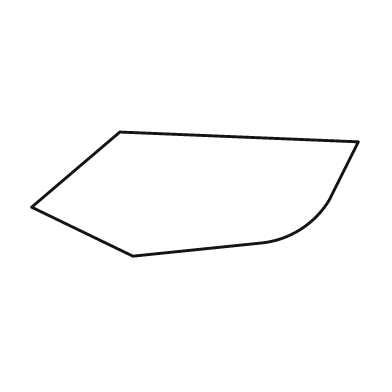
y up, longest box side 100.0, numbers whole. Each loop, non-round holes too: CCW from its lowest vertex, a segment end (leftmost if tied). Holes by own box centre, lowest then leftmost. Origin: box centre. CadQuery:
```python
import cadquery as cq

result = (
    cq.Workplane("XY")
    .moveTo(-19.0, -19.0)
    .lineTo(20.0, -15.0)
    .threePointArc((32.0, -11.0), (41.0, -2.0))
    .lineTo(50.0, 16.0)
    .lineTo(-23.0, 19.0)
    .lineTo(-50.0, -4.0)
    .close()
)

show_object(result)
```